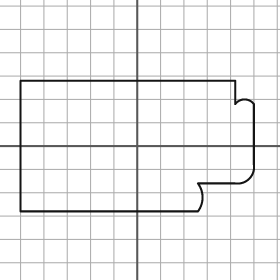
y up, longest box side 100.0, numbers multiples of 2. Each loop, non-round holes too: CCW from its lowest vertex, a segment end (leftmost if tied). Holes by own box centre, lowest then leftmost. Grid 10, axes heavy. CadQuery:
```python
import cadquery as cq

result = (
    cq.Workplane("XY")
    .moveTo(-50.0, -28.0)
    .lineTo(26.0, -28.0)
    .threePointArc((28.0, -22.0), (26.0, -16.0))
    .lineTo(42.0, -16.0)
    .threePointArc((48.0, -14.0), (50.0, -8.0))
    .lineTo(50.0, 18.0)
    .threePointArc((46.0, 20.0), (42.0, 18.0))
    .lineTo(42.0, 28.0)
    .lineTo(-50.0, 28.0)
    .close()
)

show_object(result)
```